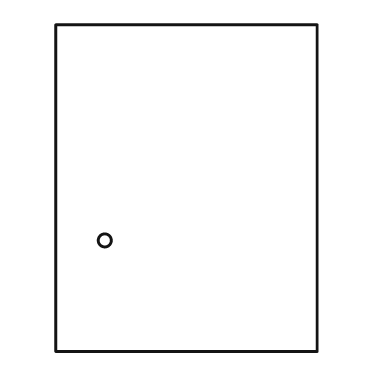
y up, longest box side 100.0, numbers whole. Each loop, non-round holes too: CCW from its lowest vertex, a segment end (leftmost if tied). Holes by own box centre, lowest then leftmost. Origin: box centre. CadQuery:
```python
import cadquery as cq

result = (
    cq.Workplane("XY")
    .moveTo(-40.0, -50.0)
    .lineTo(40.0, -50.0)
    .lineTo(40.0, 50.0)
    .lineTo(-40.0, 50.0)
    .close()
    .moveTo(-25.0, -16.0)
    .circle(2.0)
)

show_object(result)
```